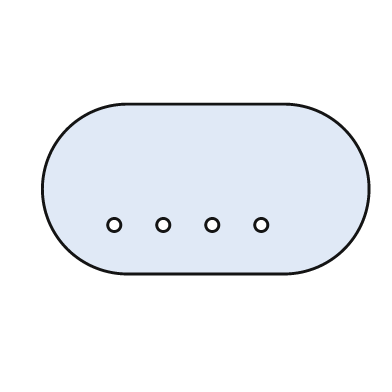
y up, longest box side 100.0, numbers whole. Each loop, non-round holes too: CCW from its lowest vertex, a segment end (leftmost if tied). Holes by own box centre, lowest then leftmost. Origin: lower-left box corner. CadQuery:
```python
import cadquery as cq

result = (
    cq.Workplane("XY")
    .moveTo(26.0, 0.0)
    .lineTo(74.0, 0.0)
    .threePointArc((100.0, 26.0), (74.0, 52.0))
    .lineTo(26.0, 52.0)
    .threePointArc((0.0, 26.0), (26.0, 0.0))
    .close()
    .moveTo(22.0, 15.0)
    .circle(2.0)
    .moveTo(37.0, 15.0)
    .circle(2.0)
    .moveTo(52.0, 15.0)
    .circle(2.0)
    .moveTo(67.0, 15.0)
    .circle(2.0)
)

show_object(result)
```